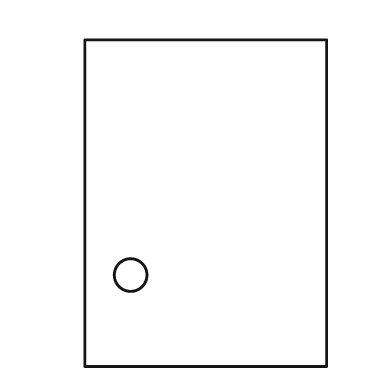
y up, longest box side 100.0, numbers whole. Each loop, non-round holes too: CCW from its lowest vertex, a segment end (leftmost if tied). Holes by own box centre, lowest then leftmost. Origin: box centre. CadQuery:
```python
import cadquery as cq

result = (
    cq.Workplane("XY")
    .moveTo(-37.0, -50.0)
    .lineTo(37.0, -50.0)
    .lineTo(37.0, 50.0)
    .lineTo(-37.0, 50.0)
    .close()
    .moveTo(-23.0, -22.0)
    .circle(5.0)
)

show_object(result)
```